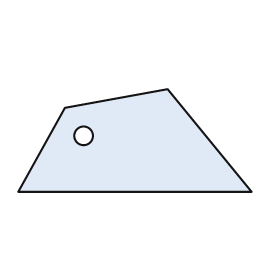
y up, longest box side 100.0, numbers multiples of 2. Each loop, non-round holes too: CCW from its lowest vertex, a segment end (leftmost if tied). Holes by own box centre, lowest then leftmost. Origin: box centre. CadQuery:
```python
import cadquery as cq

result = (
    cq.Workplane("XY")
    .moveTo(-50.0, -22.0)
    .lineTo(50.0, -22.0)
    .lineTo(14.0, 22.0)
    .lineTo(-30.0, 14.0)
    .close()
    .moveTo(-22.0, 2.0)
    .circle(4.0)
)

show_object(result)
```